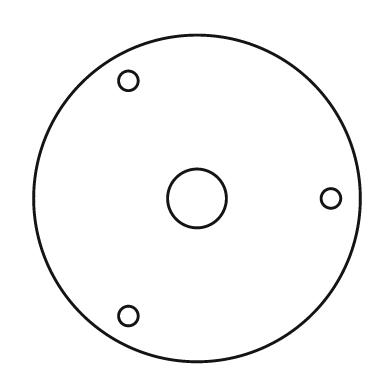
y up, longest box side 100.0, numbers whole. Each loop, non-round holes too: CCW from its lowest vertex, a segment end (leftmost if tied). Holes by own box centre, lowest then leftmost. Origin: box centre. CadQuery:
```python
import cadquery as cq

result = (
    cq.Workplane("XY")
    .moveTo(0.0, 0.0)
    .circle(50.0)
    .moveTo(-21.0, -36.0)
    .circle(3.0)
    .moveTo(0.0, 0.0)
    .circle(9.0)
    .moveTo(41.0, 0.0)
    .circle(3.0)
    .moveTo(-21.0, 36.0)
    .circle(3.0)
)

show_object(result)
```